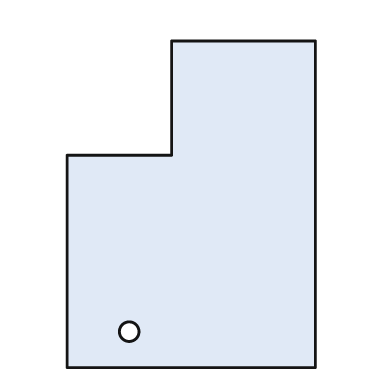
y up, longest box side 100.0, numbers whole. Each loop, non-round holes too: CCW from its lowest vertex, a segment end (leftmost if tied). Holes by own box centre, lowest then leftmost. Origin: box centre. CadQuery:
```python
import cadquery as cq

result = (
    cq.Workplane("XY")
    .moveTo(-38.0, -50.0)
    .lineTo(38.0, -50.0)
    .lineTo(38.0, 50.0)
    .lineTo(-6.0, 50.0)
    .lineTo(-6.0, 15.0)
    .lineTo(-38.0, 15.0)
    .close()
    .moveTo(-19.0, -39.0)
    .circle(3.0)
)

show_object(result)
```